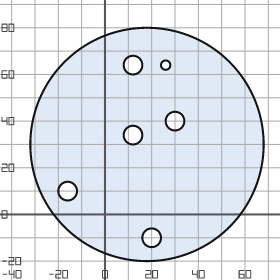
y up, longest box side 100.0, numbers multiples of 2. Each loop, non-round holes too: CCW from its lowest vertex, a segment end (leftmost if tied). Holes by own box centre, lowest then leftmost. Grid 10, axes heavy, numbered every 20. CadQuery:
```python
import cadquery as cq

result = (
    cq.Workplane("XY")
    .moveTo(18.0, 30.0)
    .circle(50.0)
    .moveTo(20.0, -10.0)
    .circle(4.0)
    .moveTo(-16.0, 10.0)
    .circle(4.0)
    .moveTo(12.0, 34.0)
    .circle(4.0)
    .moveTo(30.0, 40.0)
    .circle(4.0)
    .moveTo(12.0, 64.0)
    .circle(4.0)
    .moveTo(26.0, 64.0)
    .circle(2.0)
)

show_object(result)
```